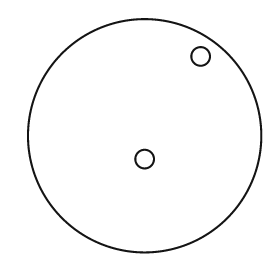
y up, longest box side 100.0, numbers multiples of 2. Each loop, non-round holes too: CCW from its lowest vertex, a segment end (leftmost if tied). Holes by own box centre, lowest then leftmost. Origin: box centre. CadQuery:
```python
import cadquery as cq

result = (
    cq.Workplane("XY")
    .moveTo(0.0, 0.0)
    .circle(50.0)
    .moveTo(0.0, -10.0)
    .circle(4.0)
    .moveTo(24.0, 34.0)
    .circle(4.0)
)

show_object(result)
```